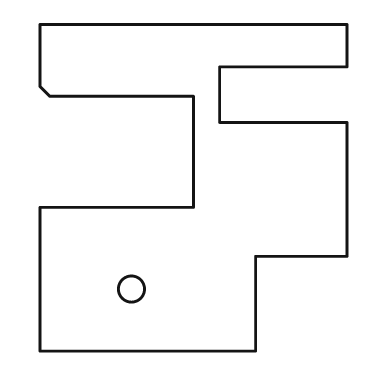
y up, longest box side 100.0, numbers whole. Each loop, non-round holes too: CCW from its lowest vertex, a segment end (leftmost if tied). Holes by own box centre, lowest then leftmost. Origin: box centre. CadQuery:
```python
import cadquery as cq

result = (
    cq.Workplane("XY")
    .moveTo(-47.0, -50.0)
    .lineTo(19.0, -50.0)
    .lineTo(19.0, -21.0)
    .lineTo(47.0, -21.0)
    .lineTo(47.0, 20.0)
    .lineTo(8.0, 20.0)
    .lineTo(8.0, 37.0)
    .lineTo(47.0, 37.0)
    .lineTo(47.0, 50.0)
    .lineTo(-47.0, 50.0)
    .lineTo(-47.0, 31.0)
    .lineTo(-44.0, 28.0)
    .lineTo(0.0, 28.0)
    .lineTo(0.0, -6.0)
    .lineTo(-47.0, -6.0)
    .close()
    .moveTo(-19.0, -31.0)
    .circle(4.0)
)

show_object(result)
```